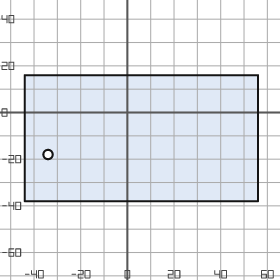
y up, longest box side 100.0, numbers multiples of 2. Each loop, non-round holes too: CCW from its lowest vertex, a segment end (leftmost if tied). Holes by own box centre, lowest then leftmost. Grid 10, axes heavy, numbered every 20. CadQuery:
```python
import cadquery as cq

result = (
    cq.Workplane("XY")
    .moveTo(-44.0, -38.0)
    .lineTo(56.0, -38.0)
    .lineTo(56.0, 16.0)
    .lineTo(-44.0, 16.0)
    .close()
    .moveTo(-34.0, -18.0)
    .circle(2.0)
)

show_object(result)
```